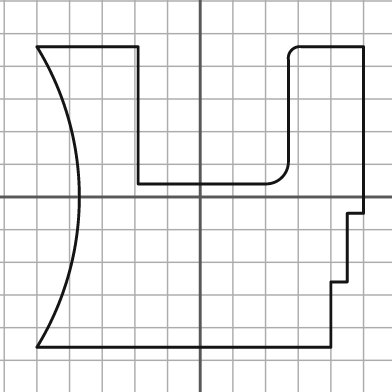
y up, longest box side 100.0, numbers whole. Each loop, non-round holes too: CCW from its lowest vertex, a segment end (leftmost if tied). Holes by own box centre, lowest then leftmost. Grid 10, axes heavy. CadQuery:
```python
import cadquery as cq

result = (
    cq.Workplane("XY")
    .moveTo(-50.0, -46.0)
    .lineTo(40.0, -46.0)
    .lineTo(40.0, -26.0)
    .lineTo(45.0, -26.0)
    .lineTo(45.0, -5.0)
    .lineTo(50.0, -5.0)
    .lineTo(50.0, 46.0)
    .lineTo(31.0, 46.0)
    .threePointArc((28.0, 45.0), (27.0, 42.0))
    .lineTo(27.0, 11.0)
    .threePointArc((25.0, 6.0), (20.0, 4.0))
    .lineTo(-19.0, 4.0)
    .lineTo(-19.0, 46.0)
    .lineTo(-50.0, 46.0)
    .threePointArc((-37.0, 0.0), (-50.0, -46.0))
    .close()
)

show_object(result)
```